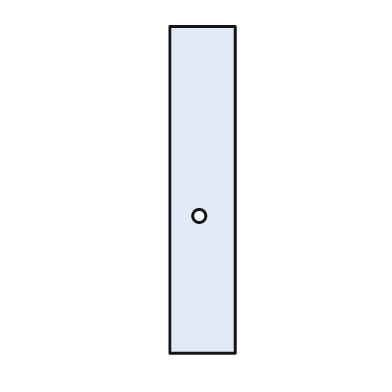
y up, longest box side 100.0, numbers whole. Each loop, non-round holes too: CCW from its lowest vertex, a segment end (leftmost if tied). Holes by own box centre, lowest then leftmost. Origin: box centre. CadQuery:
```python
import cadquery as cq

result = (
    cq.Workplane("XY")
    .moveTo(-10.0, -50.0)
    .lineTo(10.0, -50.0)
    .lineTo(10.0, 50.0)
    .lineTo(-10.0, 50.0)
    .close()
    .moveTo(-1.0, -8.0)
    .circle(2.0)
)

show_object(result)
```